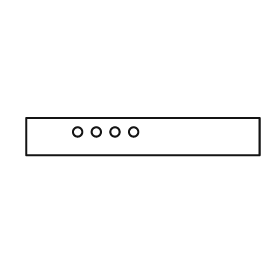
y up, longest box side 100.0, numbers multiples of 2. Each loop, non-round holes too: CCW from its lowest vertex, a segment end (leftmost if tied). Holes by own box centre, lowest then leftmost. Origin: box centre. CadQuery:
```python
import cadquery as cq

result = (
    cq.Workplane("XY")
    .moveTo(-50.0, -8.0)
    .lineTo(50.0, -8.0)
    .lineTo(50.0, 8.0)
    .lineTo(-50.0, 8.0)
    .close()
    .moveTo(-28.0, 2.0)
    .circle(2.0)
    .moveTo(-20.0, 2.0)
    .circle(2.0)
    .moveTo(-12.0, 2.0)
    .circle(2.0)
    .moveTo(-4.0, 2.0)
    .circle(2.0)
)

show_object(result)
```